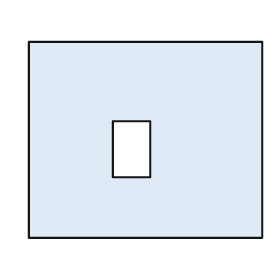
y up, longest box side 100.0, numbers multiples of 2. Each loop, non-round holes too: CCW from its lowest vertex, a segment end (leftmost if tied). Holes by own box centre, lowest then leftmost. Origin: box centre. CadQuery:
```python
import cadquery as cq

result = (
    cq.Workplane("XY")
    .moveTo(-50.0, -42.0)
    .lineTo(50.0, -42.0)
    .lineTo(50.0, 42.0)
    .lineTo(-50.0, 42.0)
    .close()
    .moveTo(-14.0, -16.0)
    .lineTo(2.0, -16.0)
    .lineTo(2.0, 8.0)
    .lineTo(-14.0, 8.0)
    .close()
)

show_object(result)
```